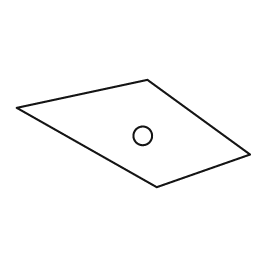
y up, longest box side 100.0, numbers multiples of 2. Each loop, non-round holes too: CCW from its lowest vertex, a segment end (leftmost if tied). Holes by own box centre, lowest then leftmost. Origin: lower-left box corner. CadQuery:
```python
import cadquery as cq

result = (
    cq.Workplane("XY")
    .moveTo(60.0, 0.0)
    .lineTo(100.0, 14.0)
    .lineTo(56.0, 46.0)
    .lineTo(0.0, 34.0)
    .close()
    .moveTo(54.0, 22.0)
    .circle(4.0)
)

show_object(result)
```